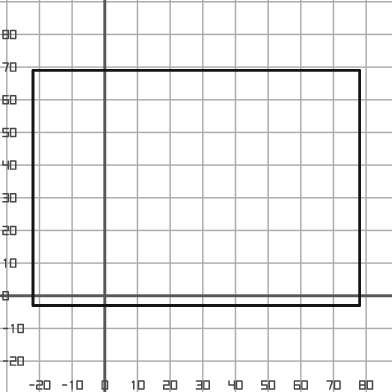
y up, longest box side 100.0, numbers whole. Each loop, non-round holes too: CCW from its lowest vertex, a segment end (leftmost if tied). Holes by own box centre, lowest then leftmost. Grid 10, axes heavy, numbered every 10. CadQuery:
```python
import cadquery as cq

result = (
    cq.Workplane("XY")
    .moveTo(-22.0, -3.0)
    .lineTo(78.0, -3.0)
    .lineTo(78.0, 69.0)
    .lineTo(-22.0, 69.0)
    .close()
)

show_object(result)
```